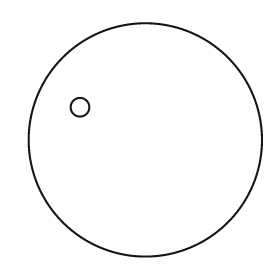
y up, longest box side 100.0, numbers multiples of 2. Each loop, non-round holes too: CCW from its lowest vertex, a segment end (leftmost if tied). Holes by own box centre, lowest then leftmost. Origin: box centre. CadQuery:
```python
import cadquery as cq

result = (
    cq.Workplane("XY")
    .moveTo(0.0, 0.0)
    .circle(50.0)
    .moveTo(-28.0, 14.0)
    .circle(4.0)
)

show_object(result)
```